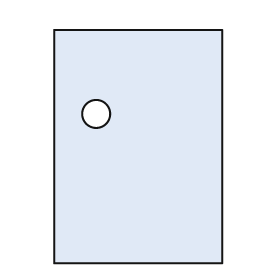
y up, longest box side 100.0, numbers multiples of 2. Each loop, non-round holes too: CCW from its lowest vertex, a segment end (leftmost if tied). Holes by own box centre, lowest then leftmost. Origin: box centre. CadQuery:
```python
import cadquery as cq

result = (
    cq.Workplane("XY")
    .moveTo(-36.0, -50.0)
    .lineTo(36.0, -50.0)
    .lineTo(36.0, 50.0)
    .lineTo(-36.0, 50.0)
    .close()
    .moveTo(-18.0, 14.0)
    .circle(6.0)
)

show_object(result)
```